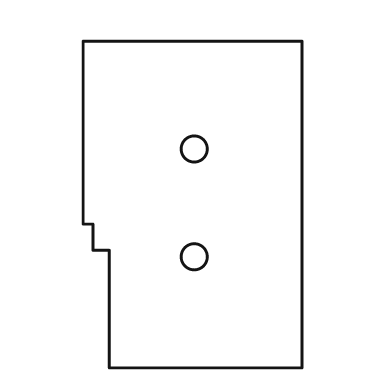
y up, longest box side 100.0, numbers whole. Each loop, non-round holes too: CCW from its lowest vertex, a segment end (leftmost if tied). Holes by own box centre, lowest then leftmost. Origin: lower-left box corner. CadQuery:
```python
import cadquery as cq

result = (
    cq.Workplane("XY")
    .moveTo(8.0, 0.0)
    .lineTo(67.0, 0.0)
    .lineTo(67.0, 100.0)
    .lineTo(0.0, 100.0)
    .lineTo(0.0, 44.0)
    .lineTo(3.0, 44.0)
    .lineTo(3.0, 36.0)
    .lineTo(8.0, 36.0)
    .close()
    .moveTo(34.0, 34.0)
    .circle(4.0)
    .moveTo(34.0, 67.0)
    .circle(4.0)
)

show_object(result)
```